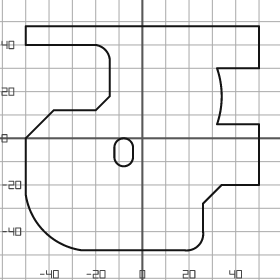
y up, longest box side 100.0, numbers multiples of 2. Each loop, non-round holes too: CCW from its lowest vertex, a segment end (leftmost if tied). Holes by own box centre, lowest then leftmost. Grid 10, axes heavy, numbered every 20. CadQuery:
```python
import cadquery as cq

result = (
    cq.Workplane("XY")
    .moveTo(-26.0, -48.0)
    .lineTo(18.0, -48.0)
    .threePointArc((24.0, -46.0), (26.0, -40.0))
    .lineTo(26.0, -28.0)
    .lineTo(34.0, -20.0)
    .lineTo(50.0, -20.0)
    .lineTo(50.0, 6.0)
    .lineTo(32.0, 6.0)
    .threePointArc((34.0, 18.0), (32.0, 30.0))
    .lineTo(50.0, 30.0)
    .lineTo(50.0, 48.0)
    .lineTo(-50.0, 48.0)
    .lineTo(-50.0, 40.0)
    .lineTo(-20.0, 40.0)
    .threePointArc((-16.0, 38.0), (-14.0, 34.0))
    .lineTo(-14.0, 18.0)
    .lineTo(-20.0, 12.0)
    .lineTo(-38.0, 12.0)
    .lineTo(-50.0, 0.0)
    .lineTo(-50.0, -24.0)
    .threePointArc((-42.0, -40.0), (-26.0, -48.0))
    .close()
    .moveTo(-12.0, -8.0)
    .threePointArc((-8.0, -12.0), (-4.0, -8.0))
    .lineTo(-4.0, -4.0)
    .threePointArc((-8.0, 0.0), (-12.0, -4.0))
    .close()
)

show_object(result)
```